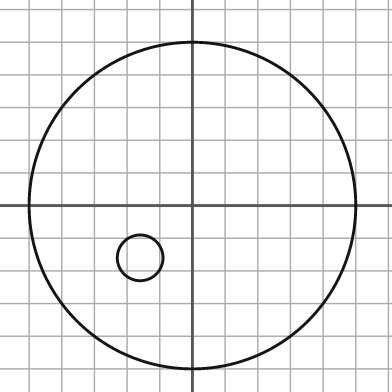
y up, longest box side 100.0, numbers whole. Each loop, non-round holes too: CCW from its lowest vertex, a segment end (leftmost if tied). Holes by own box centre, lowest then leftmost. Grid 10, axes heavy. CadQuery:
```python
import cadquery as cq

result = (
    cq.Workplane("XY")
    .moveTo(0.0, 0.0)
    .circle(50.0)
    .moveTo(-16.0, -16.0)
    .circle(7.0)
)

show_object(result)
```